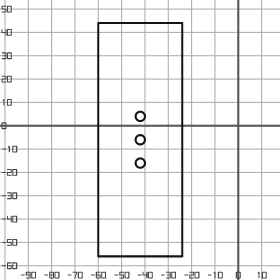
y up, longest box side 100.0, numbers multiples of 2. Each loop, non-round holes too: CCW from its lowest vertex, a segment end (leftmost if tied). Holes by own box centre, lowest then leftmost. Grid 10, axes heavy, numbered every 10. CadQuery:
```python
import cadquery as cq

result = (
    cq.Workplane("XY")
    .moveTo(-60.0, -56.0)
    .lineTo(-24.0, -56.0)
    .lineTo(-24.0, 44.0)
    .lineTo(-60.0, 44.0)
    .close()
    .moveTo(-42.0, -16.0)
    .circle(2.0)
    .moveTo(-42.0, -6.0)
    .circle(2.0)
    .moveTo(-42.0, 4.0)
    .circle(2.0)
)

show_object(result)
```